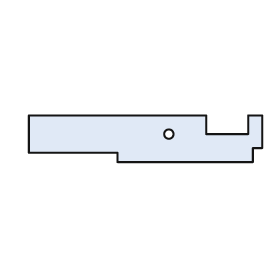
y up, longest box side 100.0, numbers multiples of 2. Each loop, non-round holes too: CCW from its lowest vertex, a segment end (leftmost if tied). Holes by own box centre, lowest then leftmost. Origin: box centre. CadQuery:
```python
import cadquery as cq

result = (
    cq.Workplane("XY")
    .moveTo(-12.0, -10.0)
    .lineTo(46.0, -10.0)
    .lineTo(46.0, -4.0)
    .lineTo(50.0, -4.0)
    .lineTo(50.0, 10.0)
    .lineTo(44.0, 10.0)
    .lineTo(44.0, 2.0)
    .lineTo(26.0, 2.0)
    .lineTo(26.0, 10.0)
    .lineTo(-50.0, 10.0)
    .lineTo(-50.0, -6.0)
    .lineTo(-12.0, -6.0)
    .close()
    .moveTo(10.0, 2.0)
    .circle(2.0)
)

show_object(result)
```